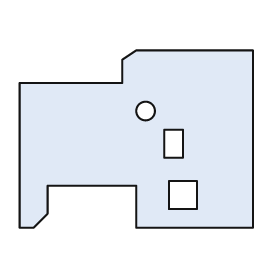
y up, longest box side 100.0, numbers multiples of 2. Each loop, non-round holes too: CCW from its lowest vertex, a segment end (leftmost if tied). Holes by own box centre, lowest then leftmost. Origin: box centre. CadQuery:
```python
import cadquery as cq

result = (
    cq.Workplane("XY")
    .moveTo(-50.0, -38.0)
    .lineTo(-44.0, -38.0)
    .lineTo(-38.0, -32.0)
    .lineTo(-38.0, -20.0)
    .lineTo(0.0, -20.0)
    .lineTo(0.0, -38.0)
    .lineTo(50.0, -38.0)
    .lineTo(50.0, 38.0)
    .lineTo(0.0, 38.0)
    .lineTo(-6.0, 34.0)
    .lineTo(-6.0, 24.0)
    .lineTo(-50.0, 24.0)
    .close()
    .moveTo(14.0, -30.0)
    .lineTo(26.0, -30.0)
    .lineTo(26.0, -18.0)
    .lineTo(14.0, -18.0)
    .close()
    .moveTo(12.0, -8.0)
    .lineTo(20.0, -8.0)
    .lineTo(20.0, 4.0)
    .lineTo(12.0, 4.0)
    .close()
    .moveTo(4.0, 12.0)
    .circle(4.0)
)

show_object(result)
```